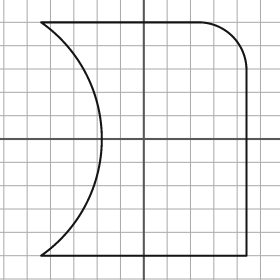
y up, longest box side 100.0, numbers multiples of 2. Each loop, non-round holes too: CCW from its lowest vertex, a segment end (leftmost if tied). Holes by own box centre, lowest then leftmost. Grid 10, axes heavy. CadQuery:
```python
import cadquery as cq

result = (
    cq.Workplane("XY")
    .moveTo(-44.0, -50.0)
    .lineTo(44.0, -50.0)
    .lineTo(44.0, 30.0)
    .threePointArc((38.0, 44.0), (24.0, 50.0))
    .lineTo(-44.0, 50.0)
    .threePointArc((-18.0, 0.0), (-44.0, -50.0))
    .close()
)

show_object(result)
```